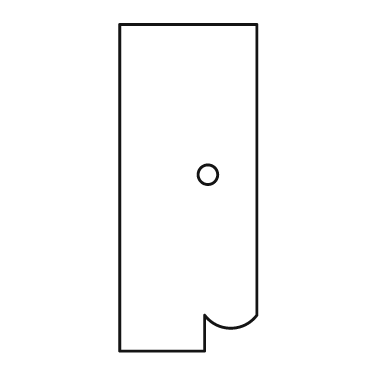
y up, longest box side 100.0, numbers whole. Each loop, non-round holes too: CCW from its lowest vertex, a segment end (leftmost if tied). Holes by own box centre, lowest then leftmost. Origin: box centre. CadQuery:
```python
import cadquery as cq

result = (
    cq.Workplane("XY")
    .moveTo(-21.0, -50.0)
    .lineTo(5.0, -50.0)
    .lineTo(5.0, -39.0)
    .threePointArc((13.0, -43.0), (21.0, -39.0))
    .lineTo(21.0, 50.0)
    .lineTo(-21.0, 50.0)
    .close()
    .moveTo(6.0, 4.0)
    .circle(3.0)
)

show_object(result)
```